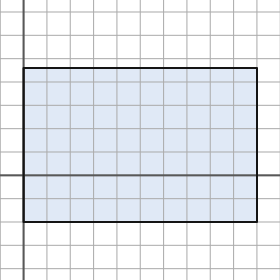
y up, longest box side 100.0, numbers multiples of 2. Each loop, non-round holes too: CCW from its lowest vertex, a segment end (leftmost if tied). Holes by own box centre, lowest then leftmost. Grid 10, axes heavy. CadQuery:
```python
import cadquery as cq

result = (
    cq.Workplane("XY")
    .moveTo(0.0, -20.0)
    .lineTo(100.0, -20.0)
    .lineTo(100.0, 46.0)
    .lineTo(0.0, 46.0)
    .close()
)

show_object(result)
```